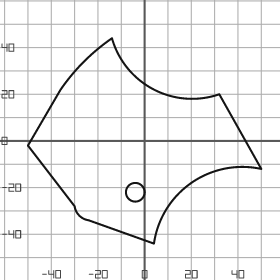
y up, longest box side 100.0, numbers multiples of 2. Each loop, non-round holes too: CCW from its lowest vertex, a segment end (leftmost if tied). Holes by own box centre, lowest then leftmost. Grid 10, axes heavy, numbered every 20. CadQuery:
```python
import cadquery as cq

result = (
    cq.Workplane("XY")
    .moveTo(4.0, -44.0)
    .threePointArc((20.0, -18.0), (50.0, -12.0))
    .lineTo(32.0, 20.0)
    .threePointArc((4.0, 22.0), (-14.0, 44.0))
    .threePointArc((-26.0, 34.0), (-36.0, 22.0))
    .lineTo(-50.0, -2.0)
    .lineTo(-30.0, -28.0)
    .threePointArc((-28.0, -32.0), (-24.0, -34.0))
    .close()
    .moveTo(-4.0, -22.0)
    .circle(4.0)
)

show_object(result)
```